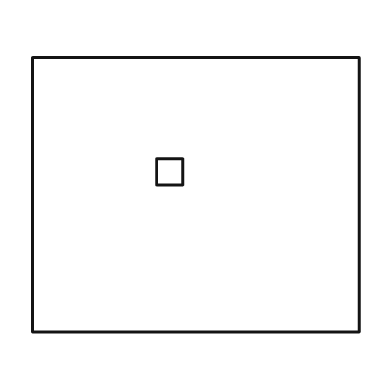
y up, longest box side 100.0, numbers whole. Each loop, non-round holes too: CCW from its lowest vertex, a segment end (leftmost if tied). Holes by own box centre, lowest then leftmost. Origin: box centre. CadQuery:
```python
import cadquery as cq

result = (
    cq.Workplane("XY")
    .moveTo(-50.0, -42.0)
    .lineTo(50.0, -42.0)
    .lineTo(50.0, 42.0)
    .lineTo(-50.0, 42.0)
    .close()
    .moveTo(-12.0, 3.0)
    .lineTo(-4.0, 3.0)
    .lineTo(-4.0, 11.0)
    .lineTo(-12.0, 11.0)
    .close()
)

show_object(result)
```